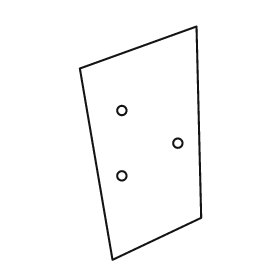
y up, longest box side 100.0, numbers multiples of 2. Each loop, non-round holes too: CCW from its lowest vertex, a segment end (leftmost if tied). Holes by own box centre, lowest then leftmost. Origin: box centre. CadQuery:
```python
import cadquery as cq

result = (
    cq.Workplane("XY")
    .moveTo(-12.0, -50.0)
    .lineTo(26.0, -32.0)
    .lineTo(24.0, 50.0)
    .lineTo(-26.0, 32.0)
    .close()
    .moveTo(-8.0, -14.0)
    .circle(2.0)
    .moveTo(16.0, 0.0)
    .circle(2.0)
    .moveTo(-8.0, 14.0)
    .circle(2.0)
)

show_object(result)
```